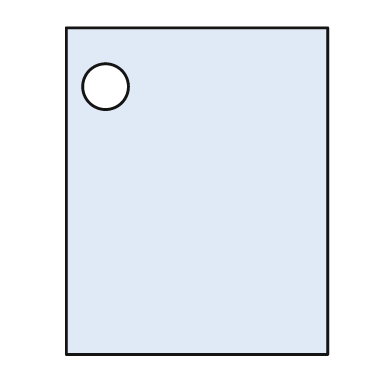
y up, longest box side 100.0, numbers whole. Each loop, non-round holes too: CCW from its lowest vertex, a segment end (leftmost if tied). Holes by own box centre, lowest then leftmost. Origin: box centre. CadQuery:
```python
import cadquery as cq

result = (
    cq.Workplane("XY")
    .moveTo(-40.0, -50.0)
    .lineTo(40.0, -50.0)
    .lineTo(40.0, 50.0)
    .lineTo(-40.0, 50.0)
    .close()
    .moveTo(-28.0, 32.0)
    .circle(7.0)
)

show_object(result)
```